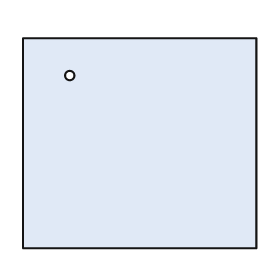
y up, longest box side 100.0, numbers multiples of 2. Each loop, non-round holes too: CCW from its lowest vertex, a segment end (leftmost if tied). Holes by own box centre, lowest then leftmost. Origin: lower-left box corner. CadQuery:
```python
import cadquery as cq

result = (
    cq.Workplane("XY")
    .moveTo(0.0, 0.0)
    .lineTo(100.0, 0.0)
    .lineTo(100.0, 90.0)
    .lineTo(0.0, 90.0)
    .close()
    .moveTo(20.0, 74.0)
    .circle(2.0)
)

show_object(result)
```